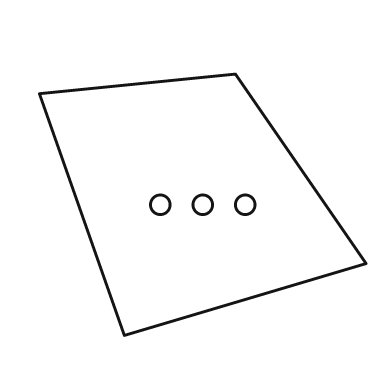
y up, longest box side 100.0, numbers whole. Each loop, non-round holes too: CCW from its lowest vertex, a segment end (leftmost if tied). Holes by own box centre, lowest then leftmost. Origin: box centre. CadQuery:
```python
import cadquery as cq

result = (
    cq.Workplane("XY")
    .moveTo(-24.0, -40.0)
    .lineTo(50.0, -18.0)
    .lineTo(10.0, 40.0)
    .lineTo(-50.0, 34.0)
    .close()
    .moveTo(-13.0, 0.0)
    .circle(3.0)
    .moveTo(0.0, 0.0)
    .circle(3.0)
    .moveTo(13.0, 0.0)
    .circle(3.0)
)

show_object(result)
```